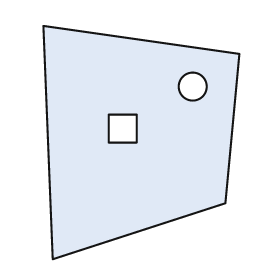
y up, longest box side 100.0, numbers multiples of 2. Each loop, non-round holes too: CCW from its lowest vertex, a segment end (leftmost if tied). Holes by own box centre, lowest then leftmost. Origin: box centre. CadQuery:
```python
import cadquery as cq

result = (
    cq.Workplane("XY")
    .moveTo(-38.0, -50.0)
    .lineTo(36.0, -26.0)
    .lineTo(42.0, 38.0)
    .lineTo(-42.0, 50.0)
    .close()
    .moveTo(-14.0, 0.0)
    .lineTo(-2.0, 0.0)
    .lineTo(-2.0, 12.0)
    .lineTo(-14.0, 12.0)
    .close()
    .moveTo(22.0, 24.0)
    .circle(6.0)
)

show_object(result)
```